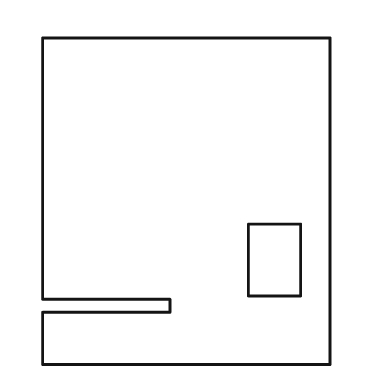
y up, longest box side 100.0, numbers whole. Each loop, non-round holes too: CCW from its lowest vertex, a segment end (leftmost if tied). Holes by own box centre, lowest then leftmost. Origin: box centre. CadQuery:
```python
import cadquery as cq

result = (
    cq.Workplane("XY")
    .moveTo(-44.0, -50.0)
    .lineTo(44.0, -50.0)
    .lineTo(44.0, 50.0)
    .lineTo(-44.0, 50.0)
    .lineTo(-44.0, -30.0)
    .lineTo(-5.0, -30.0)
    .lineTo(-5.0, -34.0)
    .lineTo(-44.0, -34.0)
    .close()
    .moveTo(19.0, -29.0)
    .lineTo(35.0, -29.0)
    .lineTo(35.0, -7.0)
    .lineTo(19.0, -7.0)
    .close()
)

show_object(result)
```